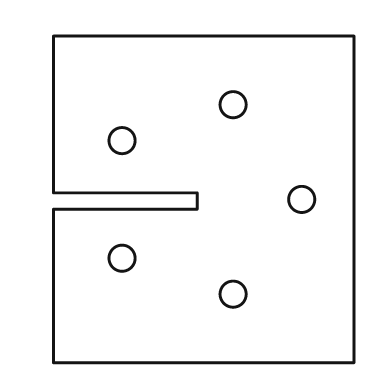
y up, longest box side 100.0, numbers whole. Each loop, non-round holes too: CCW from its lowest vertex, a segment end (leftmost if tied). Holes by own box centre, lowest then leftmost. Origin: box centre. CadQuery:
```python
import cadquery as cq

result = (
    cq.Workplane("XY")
    .moveTo(-46.0, -50.0)
    .lineTo(46.0, -50.0)
    .lineTo(46.0, 50.0)
    .lineTo(-46.0, 50.0)
    .lineTo(-46.0, 2.0)
    .lineTo(-2.0, 2.0)
    .lineTo(-2.0, -3.0)
    .lineTo(-46.0, -3.0)
    .close()
    .moveTo(9.0, -29.0)
    .circle(4.0)
    .moveTo(-25.0, -18.0)
    .circle(4.0)
    .moveTo(30.0, 0.0)
    .circle(4.0)
    .moveTo(-25.0, 18.0)
    .circle(4.0)
    .moveTo(9.0, 29.0)
    .circle(4.0)
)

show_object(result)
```